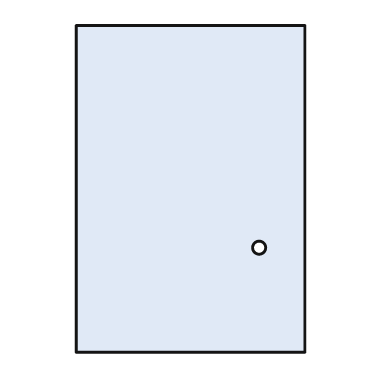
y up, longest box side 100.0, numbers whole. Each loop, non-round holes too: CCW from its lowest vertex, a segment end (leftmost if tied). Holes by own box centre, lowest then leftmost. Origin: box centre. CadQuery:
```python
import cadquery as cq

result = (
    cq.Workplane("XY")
    .moveTo(-35.0, -50.0)
    .lineTo(35.0, -50.0)
    .lineTo(35.0, 50.0)
    .lineTo(-35.0, 50.0)
    .close()
    .moveTo(21.0, -18.0)
    .circle(2.0)
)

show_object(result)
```